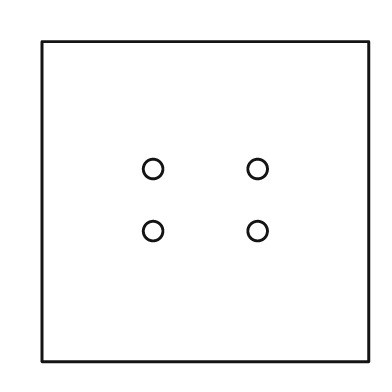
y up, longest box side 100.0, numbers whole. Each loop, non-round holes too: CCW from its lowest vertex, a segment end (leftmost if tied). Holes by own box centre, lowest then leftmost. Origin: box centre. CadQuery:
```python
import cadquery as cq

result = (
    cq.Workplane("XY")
    .moveTo(-50.0, -49.0)
    .lineTo(50.0, -49.0)
    .lineTo(50.0, 49.0)
    .lineTo(-50.0, 49.0)
    .close()
    .moveTo(-16.0, -9.0)
    .circle(3.0)
    .moveTo(16.0, -9.0)
    .circle(3.0)
    .moveTo(-16.0, 10.0)
    .circle(3.0)
    .moveTo(16.0, 10.0)
    .circle(3.0)
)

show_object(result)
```